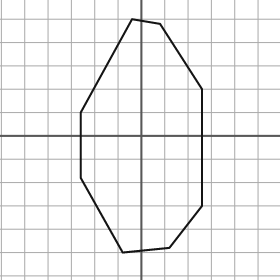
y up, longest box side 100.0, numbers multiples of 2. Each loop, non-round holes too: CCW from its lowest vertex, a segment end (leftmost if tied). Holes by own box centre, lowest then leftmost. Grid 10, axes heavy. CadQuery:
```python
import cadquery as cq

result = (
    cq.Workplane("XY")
    .moveTo(-8.0, -50.0)
    .lineTo(12.0, -48.0)
    .lineTo(26.0, -30.0)
    .lineTo(26.0, 20.0)
    .lineTo(8.0, 48.0)
    .lineTo(-4.0, 50.0)
    .lineTo(-26.0, 10.0)
    .lineTo(-26.0, -18.0)
    .close()
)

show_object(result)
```